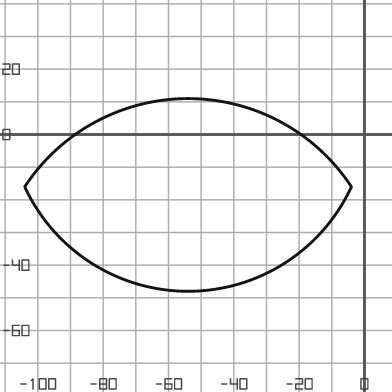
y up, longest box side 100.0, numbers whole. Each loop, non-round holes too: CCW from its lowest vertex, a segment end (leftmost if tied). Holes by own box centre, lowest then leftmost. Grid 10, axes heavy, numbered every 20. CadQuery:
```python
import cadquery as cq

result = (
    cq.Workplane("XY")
    .moveTo(-104.0, -16.0)
    .threePointArc((-54.0, -48.0), (-4.0, -16.0))
    .threePointArc((-54.0, 11.0), (-104.0, -16.0))
    .close()
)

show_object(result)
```